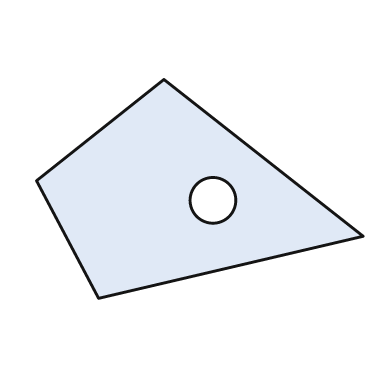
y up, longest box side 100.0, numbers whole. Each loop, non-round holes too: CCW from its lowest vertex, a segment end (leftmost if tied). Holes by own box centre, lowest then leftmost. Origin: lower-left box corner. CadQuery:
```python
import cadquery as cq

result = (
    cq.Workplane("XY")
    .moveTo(19.0, 0.0)
    .lineTo(100.0, 19.0)
    .lineTo(39.0, 67.0)
    .lineTo(0.0, 36.0)
    .close()
    .moveTo(54.0, 30.0)
    .circle(7.0)
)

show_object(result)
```